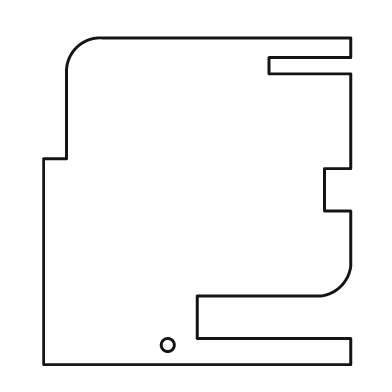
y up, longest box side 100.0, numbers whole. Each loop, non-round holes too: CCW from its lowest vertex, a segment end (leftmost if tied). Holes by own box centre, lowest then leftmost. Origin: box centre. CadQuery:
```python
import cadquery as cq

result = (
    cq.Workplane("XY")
    .moveTo(-47.0, -50.0)
    .lineTo(47.0, -50.0)
    .lineTo(47.0, -42.0)
    .lineTo(0.0, -42.0)
    .lineTo(0.0, -29.0)
    .lineTo(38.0, -29.0)
    .threePointArc((44.0, -26.0), (47.0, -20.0))
    .lineTo(47.0, -3.0)
    .lineTo(39.0, -3.0)
    .lineTo(39.0, 10.0)
    .lineTo(47.0, 10.0)
    .lineTo(47.0, 39.0)
    .lineTo(22.0, 39.0)
    .lineTo(22.0, 44.0)
    .lineTo(47.0, 44.0)
    .lineTo(47.0, 50.0)
    .lineTo(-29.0, 50.0)
    .threePointArc((-37.0, 47.0), (-40.0, 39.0))
    .lineTo(-40.0, 13.0)
    .lineTo(-47.0, 13.0)
    .close()
    .moveTo(-9.0, -44.0)
    .circle(2.0)
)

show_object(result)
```